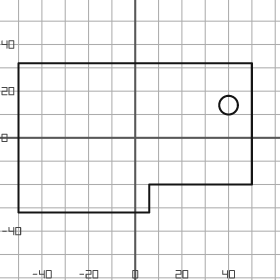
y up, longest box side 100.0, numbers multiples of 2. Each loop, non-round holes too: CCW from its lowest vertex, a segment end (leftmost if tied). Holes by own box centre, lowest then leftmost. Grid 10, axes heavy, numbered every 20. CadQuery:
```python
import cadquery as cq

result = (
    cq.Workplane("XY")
    .moveTo(-50.0, -32.0)
    .lineTo(6.0, -32.0)
    .lineTo(6.0, -20.0)
    .lineTo(50.0, -20.0)
    .lineTo(50.0, 32.0)
    .lineTo(-50.0, 32.0)
    .close()
    .moveTo(40.0, 14.0)
    .circle(4.0)
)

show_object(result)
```